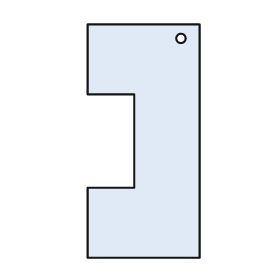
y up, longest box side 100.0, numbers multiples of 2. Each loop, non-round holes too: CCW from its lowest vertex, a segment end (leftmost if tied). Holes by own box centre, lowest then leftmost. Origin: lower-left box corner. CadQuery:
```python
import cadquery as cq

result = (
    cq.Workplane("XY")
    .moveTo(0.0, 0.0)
    .lineTo(48.0, 0.0)
    .lineTo(48.0, 100.0)
    .lineTo(0.0, 100.0)
    .lineTo(0.0, 70.0)
    .lineTo(20.0, 70.0)
    .lineTo(20.0, 30.0)
    .lineTo(0.0, 30.0)
    .close()
    .moveTo(40.0, 94.0)
    .circle(2.0)
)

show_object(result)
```